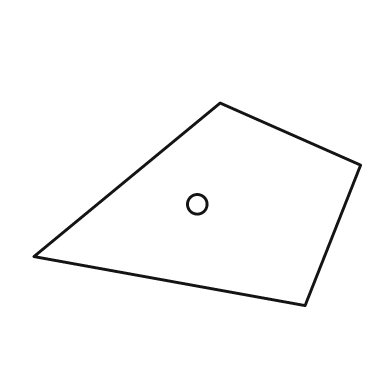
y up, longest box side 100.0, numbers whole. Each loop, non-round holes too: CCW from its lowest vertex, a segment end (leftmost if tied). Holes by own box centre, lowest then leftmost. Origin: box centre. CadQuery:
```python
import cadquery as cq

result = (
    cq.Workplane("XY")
    .moveTo(33.0, -31.0)
    .lineTo(50.0, 12.0)
    .lineTo(7.0, 31.0)
    .lineTo(-50.0, -16.0)
    .close()
    .moveTo(0.0, 0.0)
    .circle(3.0)
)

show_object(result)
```